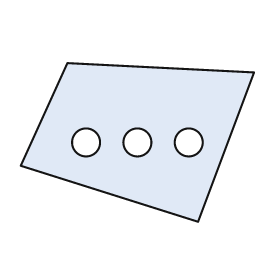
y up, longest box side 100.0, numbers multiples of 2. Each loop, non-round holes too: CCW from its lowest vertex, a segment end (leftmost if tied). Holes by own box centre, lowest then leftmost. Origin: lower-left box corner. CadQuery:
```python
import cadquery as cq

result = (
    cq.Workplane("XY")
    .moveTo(76.0, 0.0)
    .lineTo(100.0, 64.0)
    .lineTo(20.0, 68.0)
    .lineTo(0.0, 24.0)
    .close()
    .moveTo(28.0, 34.0)
    .circle(6.0)
    .moveTo(50.0, 34.0)
    .circle(6.0)
    .moveTo(72.0, 34.0)
    .circle(6.0)
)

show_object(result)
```